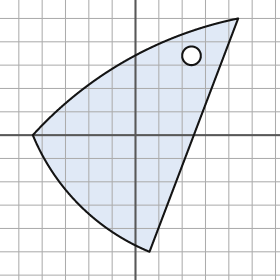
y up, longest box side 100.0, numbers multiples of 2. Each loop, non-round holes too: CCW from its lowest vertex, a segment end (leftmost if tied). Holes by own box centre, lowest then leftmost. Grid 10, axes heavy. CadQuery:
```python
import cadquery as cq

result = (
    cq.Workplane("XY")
    .moveTo(6.0, -50.0)
    .lineTo(44.0, 50.0)
    .threePointArc((-4.0, 32.0), (-44.0, 0.0))
    .threePointArc((-24.0, -30.0), (6.0, -50.0))
    .close()
    .moveTo(24.0, 34.0)
    .circle(4.0)
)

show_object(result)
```